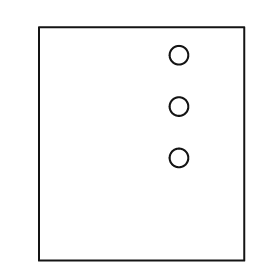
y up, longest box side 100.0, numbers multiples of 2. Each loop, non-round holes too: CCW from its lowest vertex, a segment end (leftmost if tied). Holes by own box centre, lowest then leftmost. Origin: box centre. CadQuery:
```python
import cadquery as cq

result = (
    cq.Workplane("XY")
    .moveTo(-44.0, -50.0)
    .lineTo(44.0, -50.0)
    .lineTo(44.0, 50.0)
    .lineTo(-44.0, 50.0)
    .close()
    .moveTo(16.0, -6.0)
    .circle(4.0)
    .moveTo(16.0, 16.0)
    .circle(4.0)
    .moveTo(16.0, 38.0)
    .circle(4.0)
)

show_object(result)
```